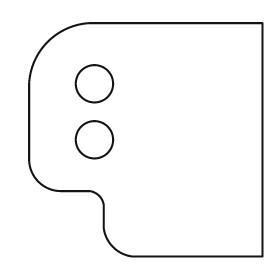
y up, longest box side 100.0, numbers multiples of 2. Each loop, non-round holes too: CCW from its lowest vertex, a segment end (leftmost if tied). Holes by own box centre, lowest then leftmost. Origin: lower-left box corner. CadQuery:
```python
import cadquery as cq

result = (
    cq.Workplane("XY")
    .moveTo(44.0, 0.0)
    .lineTo(100.0, 0.0)
    .lineTo(100.0, 100.0)
    .lineTo(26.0, 100.0)
    .threePointArc((8.0, 92.0), (0.0, 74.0))
    .lineTo(0.0, 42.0)
    .threePointArc((4.0, 32.0), (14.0, 28.0))
    .lineTo(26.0, 28.0)
    .threePointArc((30.0, 26.0), (32.0, 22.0))
    .lineTo(32.0, 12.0)
    .threePointArc((36.0, 4.0), (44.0, 0.0))
    .close()
    .moveTo(28.0, 50.0)
    .circle(8.0)
    .moveTo(28.0, 74.0)
    .circle(8.0)
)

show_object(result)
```